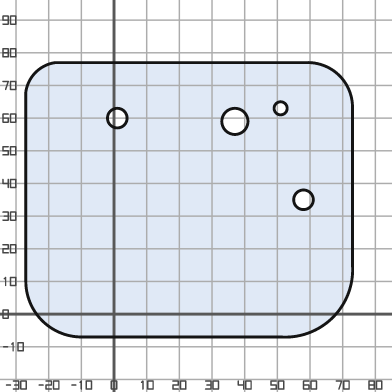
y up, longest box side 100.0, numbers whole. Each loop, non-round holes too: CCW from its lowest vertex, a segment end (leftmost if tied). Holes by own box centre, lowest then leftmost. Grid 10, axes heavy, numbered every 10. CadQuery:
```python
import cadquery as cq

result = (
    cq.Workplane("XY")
    .moveTo(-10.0, -7.0)
    .lineTo(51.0, -7.0)
    .threePointArc((67.0, -1.0), (73.0, 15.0))
    .lineTo(73.0, 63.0)
    .threePointArc((69.0, 73.0), (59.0, 77.0))
    .lineTo(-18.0, 77.0)
    .threePointArc((-24.0, 74.0), (-27.0, 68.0))
    .lineTo(-27.0, 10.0)
    .threePointArc((-22.0, -2.0), (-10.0, -7.0))
    .close()
    .moveTo(58.0, 35.0)
    .circle(3.0)
    .moveTo(37.0, 59.0)
    .circle(4.0)
    .moveTo(1.0, 60.0)
    .circle(3.0)
    .moveTo(51.0, 63.0)
    .circle(2.0)
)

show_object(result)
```